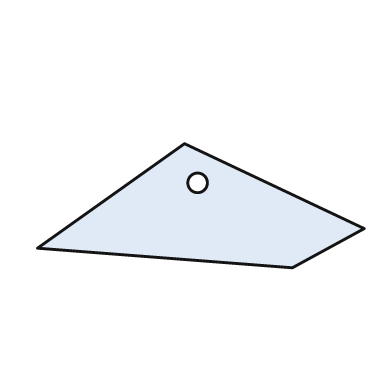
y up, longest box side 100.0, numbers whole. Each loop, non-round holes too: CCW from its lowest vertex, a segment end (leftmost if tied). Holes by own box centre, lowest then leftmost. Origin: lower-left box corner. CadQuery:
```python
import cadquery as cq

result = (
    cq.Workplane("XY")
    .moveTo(78.0, 0.0)
    .lineTo(100.0, 12.0)
    .lineTo(45.0, 38.0)
    .lineTo(0.0, 6.0)
    .close()
    .moveTo(49.0, 26.0)
    .circle(3.0)
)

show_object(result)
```